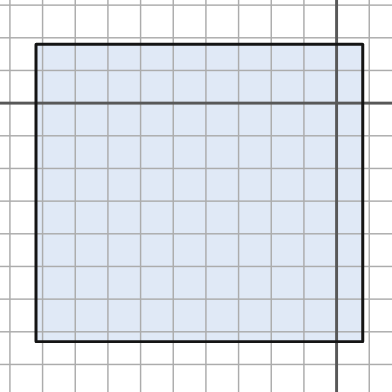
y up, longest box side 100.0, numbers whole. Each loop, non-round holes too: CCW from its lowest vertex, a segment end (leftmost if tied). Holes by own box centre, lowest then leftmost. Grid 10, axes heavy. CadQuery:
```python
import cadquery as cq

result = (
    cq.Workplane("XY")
    .moveTo(-92.0, -73.0)
    .lineTo(8.0, -73.0)
    .lineTo(8.0, 18.0)
    .lineTo(-92.0, 18.0)
    .close()
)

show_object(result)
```